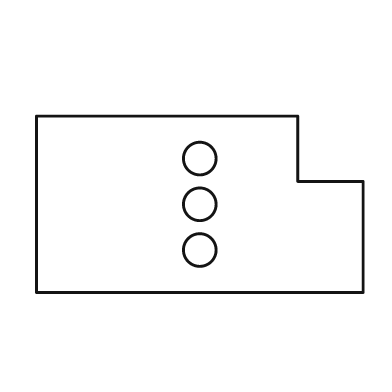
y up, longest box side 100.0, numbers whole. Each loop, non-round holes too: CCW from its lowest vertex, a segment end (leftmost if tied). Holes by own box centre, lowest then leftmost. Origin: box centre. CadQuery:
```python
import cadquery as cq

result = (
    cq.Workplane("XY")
    .moveTo(-50.0, -27.0)
    .lineTo(50.0, -27.0)
    .lineTo(50.0, 7.0)
    .lineTo(30.0, 7.0)
    .lineTo(30.0, 27.0)
    .lineTo(-50.0, 27.0)
    .close()
    .moveTo(0.0, -14.0)
    .circle(5.0)
    .moveTo(0.0, 0.0)
    .circle(5.0)
    .moveTo(0.0, 14.0)
    .circle(5.0)
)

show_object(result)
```